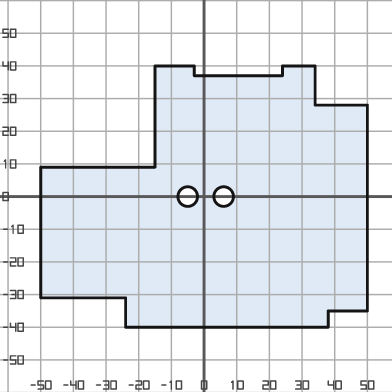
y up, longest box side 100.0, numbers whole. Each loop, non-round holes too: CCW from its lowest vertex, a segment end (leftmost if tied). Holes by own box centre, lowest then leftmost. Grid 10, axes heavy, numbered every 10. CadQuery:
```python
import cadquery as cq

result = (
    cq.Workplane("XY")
    .moveTo(-24.0, -40.0)
    .lineTo(38.0, -40.0)
    .lineTo(38.0, -35.0)
    .lineTo(50.0, -35.0)
    .lineTo(50.0, 28.0)
    .lineTo(34.0, 28.0)
    .lineTo(34.0, 40.0)
    .lineTo(24.0, 40.0)
    .lineTo(24.0, 37.0)
    .lineTo(-3.0, 37.0)
    .lineTo(-3.0, 40.0)
    .lineTo(-15.0, 40.0)
    .lineTo(-15.0, 9.0)
    .lineTo(-50.0, 9.0)
    .lineTo(-50.0, -31.0)
    .lineTo(-24.0, -31.0)
    .close()
    .moveTo(-5.0, 0.0)
    .circle(3.0)
    .moveTo(6.0, 0.0)
    .circle(3.0)
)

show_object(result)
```